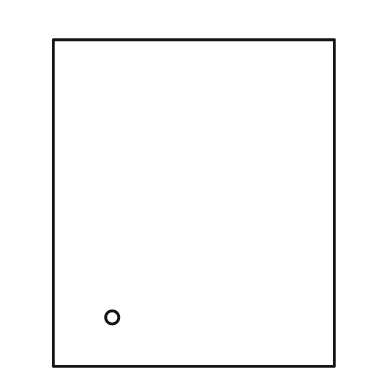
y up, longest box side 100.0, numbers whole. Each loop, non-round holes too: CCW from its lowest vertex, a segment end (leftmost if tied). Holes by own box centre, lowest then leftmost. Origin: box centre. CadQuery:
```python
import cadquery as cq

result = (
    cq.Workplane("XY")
    .moveTo(-43.0, -50.0)
    .lineTo(43.0, -50.0)
    .lineTo(43.0, 50.0)
    .lineTo(-43.0, 50.0)
    .close()
    .moveTo(-25.0, -35.0)
    .circle(2.0)
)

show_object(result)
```